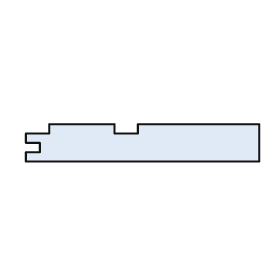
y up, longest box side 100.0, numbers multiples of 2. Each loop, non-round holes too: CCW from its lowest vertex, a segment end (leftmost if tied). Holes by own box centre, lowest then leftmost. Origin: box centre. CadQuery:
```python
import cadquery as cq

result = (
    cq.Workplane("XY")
    .moveTo(-50.0, -8.0)
    .lineTo(50.0, -8.0)
    .lineTo(50.0, 8.0)
    .lineTo(-2.0, 8.0)
    .lineTo(-2.0, 4.0)
    .lineTo(-12.0, 4.0)
    .lineTo(-12.0, 8.0)
    .lineTo(-40.0, 8.0)
    .lineTo(-40.0, 4.0)
    .lineTo(-50.0, 4.0)
    .lineTo(-50.0, 0.0)
    .lineTo(-44.0, 0.0)
    .lineTo(-44.0, -4.0)
    .lineTo(-50.0, -4.0)
    .close()
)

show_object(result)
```